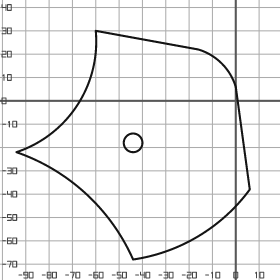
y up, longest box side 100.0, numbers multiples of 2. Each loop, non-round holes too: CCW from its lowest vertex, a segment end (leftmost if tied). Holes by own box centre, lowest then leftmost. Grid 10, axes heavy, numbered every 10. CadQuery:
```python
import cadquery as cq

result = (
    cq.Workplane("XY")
    .moveTo(-44.0, -68.0)
    .threePointArc((-16.0, -58.0), (6.0, -38.0))
    .lineTo(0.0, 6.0)
    .threePointArc((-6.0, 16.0), (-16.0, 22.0))
    .lineTo(-60.0, 30.0)
    .threePointArc((-68.0, -2.0), (-94.0, -22.0))
    .threePointArc((-64.0, -40.0), (-44.0, -68.0))
    .close()
    .moveTo(-44.0, -18.0)
    .circle(4.0)
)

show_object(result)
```